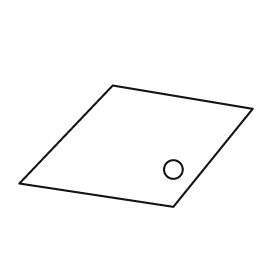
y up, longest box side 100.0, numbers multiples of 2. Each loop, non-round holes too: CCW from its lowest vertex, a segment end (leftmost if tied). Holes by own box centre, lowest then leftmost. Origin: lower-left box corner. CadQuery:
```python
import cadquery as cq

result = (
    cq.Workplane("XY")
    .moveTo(66.0, 0.0)
    .lineTo(100.0, 42.0)
    .lineTo(40.0, 52.0)
    .lineTo(0.0, 10.0)
    .close()
    .moveTo(66.0, 16.0)
    .circle(4.0)
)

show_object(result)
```